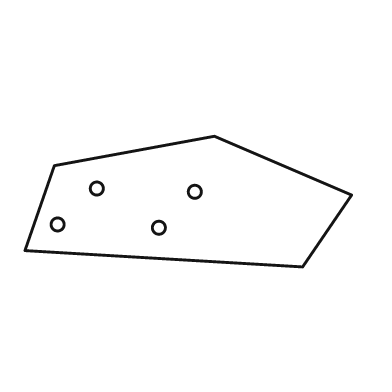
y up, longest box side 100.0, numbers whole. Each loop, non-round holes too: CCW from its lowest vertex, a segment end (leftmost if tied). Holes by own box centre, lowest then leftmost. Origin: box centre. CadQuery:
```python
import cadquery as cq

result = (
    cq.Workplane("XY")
    .moveTo(35.0, -20.0)
    .lineTo(50.0, 2.0)
    .lineTo(8.0, 20.0)
    .lineTo(-41.0, 11.0)
    .lineTo(-50.0, -15.0)
    .close()
    .moveTo(-9.0, -8.0)
    .circle(2.0)
    .moveTo(-40.0, -7.0)
    .circle(2.0)
    .moveTo(2.0, 3.0)
    .circle(2.0)
    .moveTo(-28.0, 4.0)
    .circle(2.0)
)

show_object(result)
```